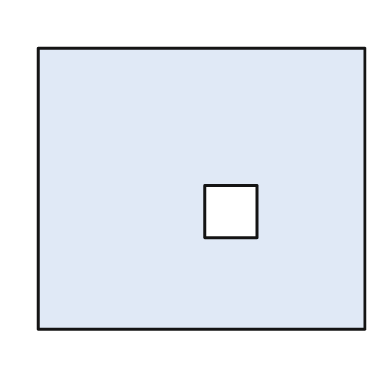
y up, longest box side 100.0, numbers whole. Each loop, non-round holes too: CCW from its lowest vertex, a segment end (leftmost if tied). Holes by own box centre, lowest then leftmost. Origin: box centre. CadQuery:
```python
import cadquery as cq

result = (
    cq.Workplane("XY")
    .moveTo(-50.0, -43.0)
    .lineTo(50.0, -43.0)
    .lineTo(50.0, 43.0)
    .lineTo(-50.0, 43.0)
    .close()
    .moveTo(1.0, -15.0)
    .lineTo(17.0, -15.0)
    .lineTo(17.0, 1.0)
    .lineTo(1.0, 1.0)
    .close()
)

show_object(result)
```